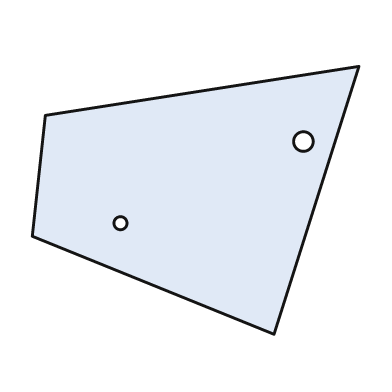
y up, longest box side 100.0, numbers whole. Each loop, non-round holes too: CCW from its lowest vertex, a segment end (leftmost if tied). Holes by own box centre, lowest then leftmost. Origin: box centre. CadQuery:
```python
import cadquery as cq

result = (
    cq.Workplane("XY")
    .moveTo(24.0, -41.0)
    .lineTo(50.0, 41.0)
    .lineTo(-46.0, 26.0)
    .lineTo(-50.0, -11.0)
    .close()
    .moveTo(-23.0, -7.0)
    .circle(2.0)
    .moveTo(33.0, 18.0)
    .circle(3.0)
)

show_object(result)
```